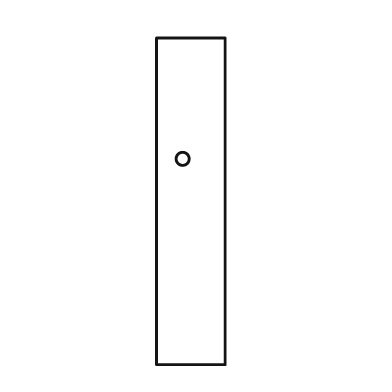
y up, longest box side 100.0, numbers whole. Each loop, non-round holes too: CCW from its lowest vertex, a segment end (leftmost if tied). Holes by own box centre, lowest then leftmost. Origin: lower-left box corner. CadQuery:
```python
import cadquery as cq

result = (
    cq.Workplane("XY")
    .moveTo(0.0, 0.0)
    .lineTo(21.0, 0.0)
    .lineTo(21.0, 100.0)
    .lineTo(0.0, 100.0)
    .close()
    .moveTo(8.0, 63.0)
    .circle(2.0)
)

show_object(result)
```